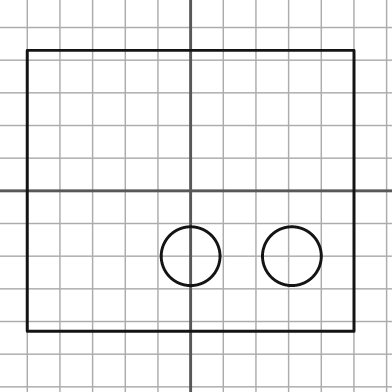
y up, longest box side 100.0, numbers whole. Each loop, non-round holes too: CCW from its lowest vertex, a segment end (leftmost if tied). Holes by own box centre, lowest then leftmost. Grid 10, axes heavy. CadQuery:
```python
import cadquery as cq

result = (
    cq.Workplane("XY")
    .moveTo(-50.0, -43.0)
    .lineTo(50.0, -43.0)
    .lineTo(50.0, 43.0)
    .lineTo(-50.0, 43.0)
    .close()
    .moveTo(0.0, -20.0)
    .circle(9.0)
    .moveTo(31.0, -20.0)
    .circle(9.0)
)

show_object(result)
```